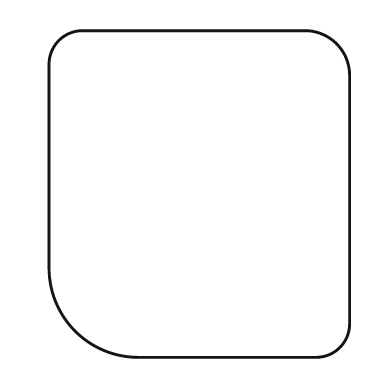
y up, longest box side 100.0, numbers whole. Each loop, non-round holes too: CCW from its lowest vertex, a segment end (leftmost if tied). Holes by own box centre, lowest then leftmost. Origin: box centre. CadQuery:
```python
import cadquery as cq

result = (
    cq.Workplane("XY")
    .moveTo(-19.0, -50.0)
    .lineTo(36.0, -50.0)
    .threePointArc((43.0, -47.0), (46.0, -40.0))
    .lineTo(46.0, 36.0)
    .threePointArc((42.0, 46.0), (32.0, 50.0))
    .lineTo(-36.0, 50.0)
    .threePointArc((-43.0, 47.0), (-46.0, 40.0))
    .lineTo(-46.0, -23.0)
    .threePointArc((-38.0, -42.0), (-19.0, -50.0))
    .close()
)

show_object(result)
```